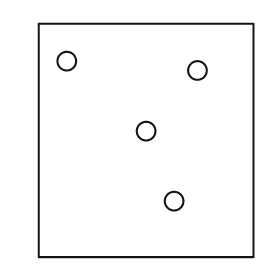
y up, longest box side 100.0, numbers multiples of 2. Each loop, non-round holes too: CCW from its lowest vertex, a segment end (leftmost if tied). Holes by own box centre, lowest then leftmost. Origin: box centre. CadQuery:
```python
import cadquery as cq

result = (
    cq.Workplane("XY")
    .moveTo(-46.0, -50.0)
    .lineTo(46.0, -50.0)
    .lineTo(46.0, 50.0)
    .lineTo(-46.0, 50.0)
    .close()
    .moveTo(12.0, -26.0)
    .circle(4.0)
    .moveTo(0.0, 4.0)
    .circle(4.0)
    .moveTo(22.0, 30.0)
    .circle(4.0)
    .moveTo(-34.0, 34.0)
    .circle(4.0)
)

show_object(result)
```